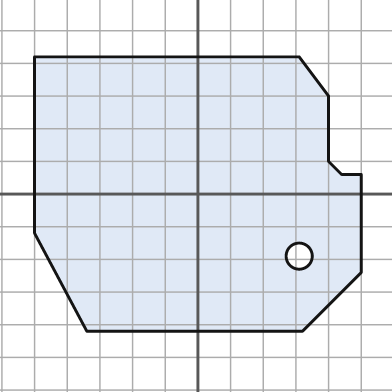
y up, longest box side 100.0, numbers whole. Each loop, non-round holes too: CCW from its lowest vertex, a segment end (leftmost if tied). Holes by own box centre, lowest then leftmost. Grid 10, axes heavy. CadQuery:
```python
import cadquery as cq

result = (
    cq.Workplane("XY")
    .moveTo(-34.0, -42.0)
    .lineTo(32.0, -42.0)
    .lineTo(50.0, -24.0)
    .lineTo(50.0, 6.0)
    .lineTo(44.0, 6.0)
    .lineTo(40.0, 10.0)
    .lineTo(40.0, 30.0)
    .lineTo(31.0, 42.0)
    .lineTo(-50.0, 42.0)
    .lineTo(-50.0, -12.0)
    .close()
    .moveTo(31.0, -19.0)
    .circle(4.0)
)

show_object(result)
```